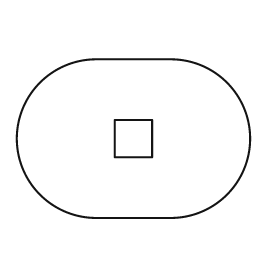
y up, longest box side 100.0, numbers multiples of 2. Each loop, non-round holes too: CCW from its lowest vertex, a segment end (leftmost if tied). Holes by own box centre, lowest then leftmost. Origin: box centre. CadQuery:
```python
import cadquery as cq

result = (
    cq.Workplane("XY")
    .moveTo(-16.0, -34.0)
    .lineTo(16.0, -34.0)
    .threePointArc((50.0, 0.0), (16.0, 34.0))
    .lineTo(-16.0, 34.0)
    .threePointArc((-50.0, 0.0), (-16.0, -34.0))
    .close()
    .moveTo(-8.0, -8.0)
    .lineTo(8.0, -8.0)
    .lineTo(8.0, 8.0)
    .lineTo(-8.0, 8.0)
    .close()
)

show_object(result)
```